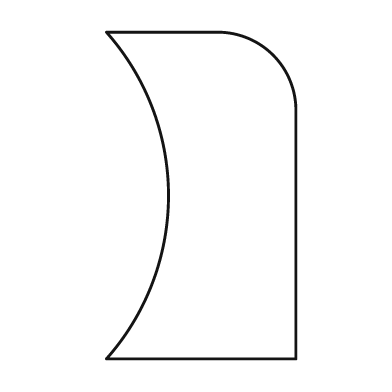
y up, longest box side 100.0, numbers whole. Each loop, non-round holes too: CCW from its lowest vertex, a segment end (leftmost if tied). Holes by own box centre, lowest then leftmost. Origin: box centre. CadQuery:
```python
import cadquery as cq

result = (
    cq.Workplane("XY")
    .moveTo(-29.0, -50.0)
    .lineTo(29.0, -50.0)
    .lineTo(29.0, 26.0)
    .threePointArc((22.0, 43.0), (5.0, 50.0))
    .lineTo(-29.0, 50.0)
    .threePointArc((-10.0, 0.0), (-29.0, -50.0))
    .close()
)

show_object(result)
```